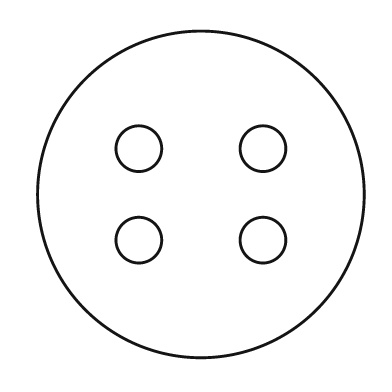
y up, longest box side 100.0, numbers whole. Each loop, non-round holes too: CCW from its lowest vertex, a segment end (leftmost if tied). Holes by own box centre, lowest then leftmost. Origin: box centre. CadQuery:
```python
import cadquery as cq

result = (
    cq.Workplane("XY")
    .moveTo(0.0, 0.0)
    .circle(50.0)
    .moveTo(-19.0, -14.0)
    .circle(7.0)
    .moveTo(19.0, -14.0)
    .circle(7.0)
    .moveTo(-19.0, 14.0)
    .circle(7.0)
    .moveTo(19.0, 14.0)
    .circle(7.0)
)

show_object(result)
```